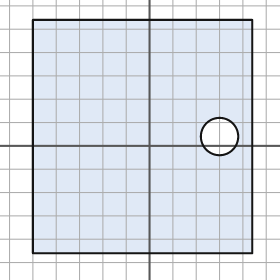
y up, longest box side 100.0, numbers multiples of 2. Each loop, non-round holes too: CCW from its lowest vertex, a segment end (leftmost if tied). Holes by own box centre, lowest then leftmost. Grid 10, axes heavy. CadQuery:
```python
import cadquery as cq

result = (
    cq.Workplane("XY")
    .moveTo(-50.0, -46.0)
    .lineTo(44.0, -46.0)
    .lineTo(44.0, 54.0)
    .lineTo(-50.0, 54.0)
    .close()
    .moveTo(30.0, 4.0)
    .circle(8.0)
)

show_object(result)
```